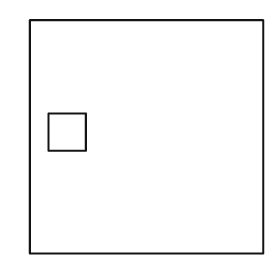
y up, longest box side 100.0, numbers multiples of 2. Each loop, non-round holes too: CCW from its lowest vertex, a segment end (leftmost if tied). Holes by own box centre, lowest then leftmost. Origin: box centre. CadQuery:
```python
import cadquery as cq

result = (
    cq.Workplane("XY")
    .moveTo(-50.0, -50.0)
    .lineTo(50.0, -50.0)
    .lineTo(50.0, 50.0)
    .lineTo(-50.0, 50.0)
    .close()
    .moveTo(-42.0, -6.0)
    .lineTo(-26.0, -6.0)
    .lineTo(-26.0, 10.0)
    .lineTo(-42.0, 10.0)
    .close()
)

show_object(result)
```